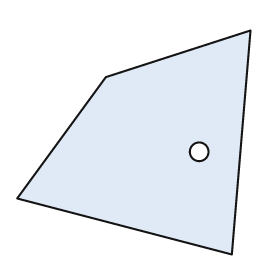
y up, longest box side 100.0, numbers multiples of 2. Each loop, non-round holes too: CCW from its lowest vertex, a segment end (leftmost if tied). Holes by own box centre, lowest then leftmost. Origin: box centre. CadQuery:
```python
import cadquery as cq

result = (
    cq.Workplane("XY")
    .moveTo(42.0, -48.0)
    .lineTo(50.0, 48.0)
    .lineTo(-12.0, 28.0)
    .lineTo(-50.0, -24.0)
    .close()
    .moveTo(28.0, -4.0)
    .circle(4.0)
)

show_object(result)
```